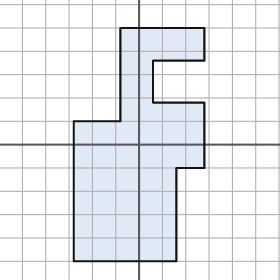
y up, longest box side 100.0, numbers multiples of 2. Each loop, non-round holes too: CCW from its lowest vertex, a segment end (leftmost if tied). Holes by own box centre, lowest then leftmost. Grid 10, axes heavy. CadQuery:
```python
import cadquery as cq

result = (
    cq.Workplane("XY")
    .moveTo(-28.0, -50.0)
    .lineTo(16.0, -50.0)
    .lineTo(16.0, -10.0)
    .lineTo(28.0, -10.0)
    .lineTo(28.0, 18.0)
    .lineTo(6.0, 18.0)
    .lineTo(6.0, 36.0)
    .lineTo(28.0, 36.0)
    .lineTo(28.0, 50.0)
    .lineTo(-8.0, 50.0)
    .lineTo(-8.0, 10.0)
    .lineTo(-28.0, 10.0)
    .close()
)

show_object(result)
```